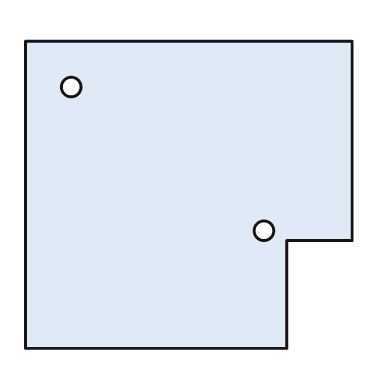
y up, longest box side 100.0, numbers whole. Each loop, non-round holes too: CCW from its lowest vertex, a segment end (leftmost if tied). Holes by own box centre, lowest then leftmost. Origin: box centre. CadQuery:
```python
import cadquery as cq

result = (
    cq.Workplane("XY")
    .moveTo(-50.0, -47.0)
    .lineTo(30.0, -47.0)
    .lineTo(30.0, -14.0)
    .lineTo(50.0, -14.0)
    .lineTo(50.0, 47.0)
    .lineTo(-50.0, 47.0)
    .close()
    .moveTo(23.0, -11.0)
    .circle(3.0)
    .moveTo(-36.0, 33.0)
    .circle(3.0)
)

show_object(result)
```